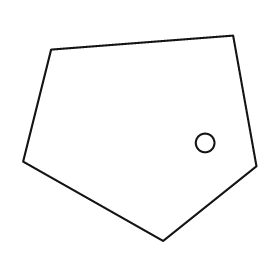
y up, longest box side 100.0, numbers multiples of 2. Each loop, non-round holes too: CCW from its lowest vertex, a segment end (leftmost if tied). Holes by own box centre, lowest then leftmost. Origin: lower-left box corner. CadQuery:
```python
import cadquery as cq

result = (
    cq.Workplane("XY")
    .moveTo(60.0, 0.0)
    .lineTo(100.0, 32.0)
    .lineTo(90.0, 88.0)
    .lineTo(12.0, 82.0)
    .lineTo(0.0, 34.0)
    .close()
    .moveTo(78.0, 42.0)
    .circle(4.0)
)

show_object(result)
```